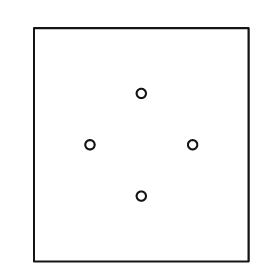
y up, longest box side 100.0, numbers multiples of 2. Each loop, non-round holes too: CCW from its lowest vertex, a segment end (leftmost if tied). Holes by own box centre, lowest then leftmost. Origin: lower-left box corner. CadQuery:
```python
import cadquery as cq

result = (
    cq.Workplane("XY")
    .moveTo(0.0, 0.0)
    .lineTo(92.0, 0.0)
    .lineTo(92.0, 100.0)
    .lineTo(0.0, 100.0)
    .close()
    .moveTo(46.0, 28.0)
    .circle(2.0)
    .moveTo(24.0, 50.0)
    .circle(2.0)
    .moveTo(68.0, 50.0)
    .circle(2.0)
    .moveTo(46.0, 72.0)
    .circle(2.0)
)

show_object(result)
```